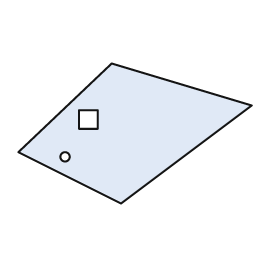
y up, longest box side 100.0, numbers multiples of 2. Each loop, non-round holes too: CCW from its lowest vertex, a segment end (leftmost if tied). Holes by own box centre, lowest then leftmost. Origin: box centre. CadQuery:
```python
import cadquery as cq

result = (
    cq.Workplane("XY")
    .moveTo(-6.0, -30.0)
    .lineTo(50.0, 12.0)
    .lineTo(-10.0, 30.0)
    .lineTo(-50.0, -8.0)
    .close()
    .moveTo(-30.0, -10.0)
    .circle(2.0)
    .moveTo(-24.0, 2.0)
    .lineTo(-16.0, 2.0)
    .lineTo(-16.0, 10.0)
    .lineTo(-24.0, 10.0)
    .close()
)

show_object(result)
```